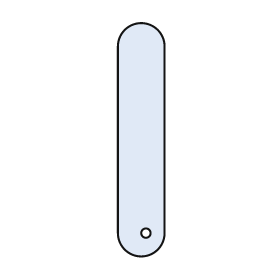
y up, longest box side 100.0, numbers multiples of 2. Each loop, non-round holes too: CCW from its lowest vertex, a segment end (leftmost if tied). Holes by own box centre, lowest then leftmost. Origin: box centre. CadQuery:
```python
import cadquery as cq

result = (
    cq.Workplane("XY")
    .moveTo(-10.0, -40.0)
    .threePointArc((0.0, -50.0), (10.0, -40.0))
    .lineTo(10.0, 40.0)
    .threePointArc((0.0, 50.0), (-10.0, 40.0))
    .close()
    .moveTo(2.0, -40.0)
    .circle(2.0)
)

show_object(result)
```